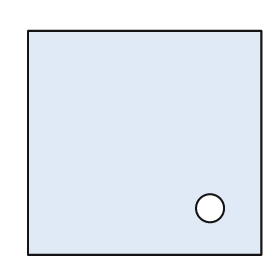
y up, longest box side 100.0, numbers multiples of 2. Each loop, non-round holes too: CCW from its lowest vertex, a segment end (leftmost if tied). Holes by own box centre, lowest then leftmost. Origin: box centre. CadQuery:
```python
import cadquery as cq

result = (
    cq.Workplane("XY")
    .moveTo(-50.0, -48.0)
    .lineTo(50.0, -48.0)
    .lineTo(50.0, 48.0)
    .lineTo(-50.0, 48.0)
    .close()
    .moveTo(28.0, -28.0)
    .circle(6.0)
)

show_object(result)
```